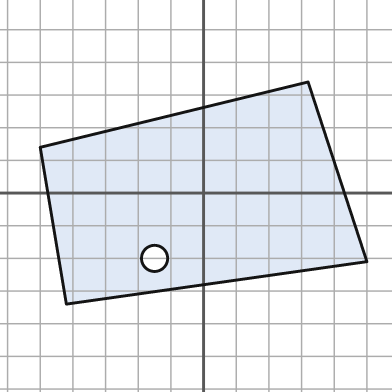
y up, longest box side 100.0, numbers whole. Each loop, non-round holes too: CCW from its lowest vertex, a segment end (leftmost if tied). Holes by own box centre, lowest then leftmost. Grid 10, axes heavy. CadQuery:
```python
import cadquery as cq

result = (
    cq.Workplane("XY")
    .moveTo(-42.0, -34.0)
    .lineTo(50.0, -21.0)
    .lineTo(32.0, 34.0)
    .lineTo(-50.0, 14.0)
    .close()
    .moveTo(-15.0, -20.0)
    .circle(4.0)
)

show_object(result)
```